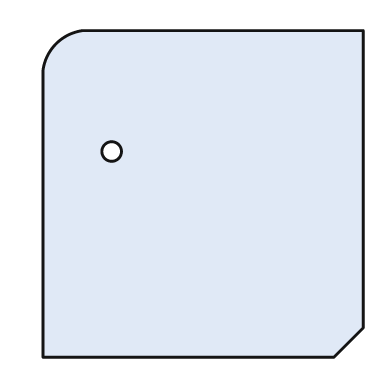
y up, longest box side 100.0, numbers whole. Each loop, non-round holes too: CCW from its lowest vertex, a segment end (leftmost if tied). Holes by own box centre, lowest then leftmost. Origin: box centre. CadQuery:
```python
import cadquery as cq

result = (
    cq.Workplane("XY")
    .moveTo(-49.0, -50.0)
    .lineTo(40.0, -50.0)
    .lineTo(49.0, -41.0)
    .lineTo(49.0, 50.0)
    .lineTo(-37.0, 50.0)
    .threePointArc((-45.0, 46.0), (-49.0, 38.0))
    .close()
    .moveTo(-28.0, 13.0)
    .circle(3.0)
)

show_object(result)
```